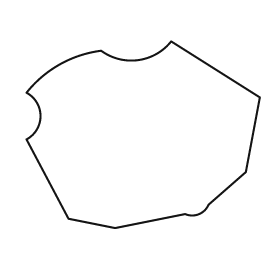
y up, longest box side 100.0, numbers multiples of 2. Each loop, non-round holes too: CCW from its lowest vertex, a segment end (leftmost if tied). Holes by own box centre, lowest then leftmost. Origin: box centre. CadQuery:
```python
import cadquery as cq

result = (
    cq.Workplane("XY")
    .moveTo(-12.0, -40.0)
    .lineTo(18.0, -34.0)
    .threePointArc((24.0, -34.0), (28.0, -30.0))
    .lineTo(44.0, -16.0)
    .lineTo(50.0, 16.0)
    .lineTo(12.0, 40.0)
    .threePointArc((-2.0, 32.0), (-18.0, 36.0))
    .threePointArc((-36.0, 30.0), (-50.0, 18.0))
    .threePointArc((-44.0, 8.0), (-50.0, -2.0))
    .lineTo(-32.0, -36.0)
    .close()
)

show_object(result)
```